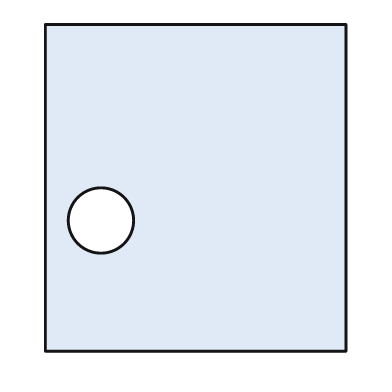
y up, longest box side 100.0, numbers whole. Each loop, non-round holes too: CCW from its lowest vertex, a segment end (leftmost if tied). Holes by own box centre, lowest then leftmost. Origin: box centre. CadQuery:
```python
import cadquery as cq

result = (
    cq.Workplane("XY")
    .moveTo(-46.0, -50.0)
    .lineTo(46.0, -50.0)
    .lineTo(46.0, 50.0)
    .lineTo(-46.0, 50.0)
    .close()
    .moveTo(-29.0, -10.0)
    .circle(10.0)
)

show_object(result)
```